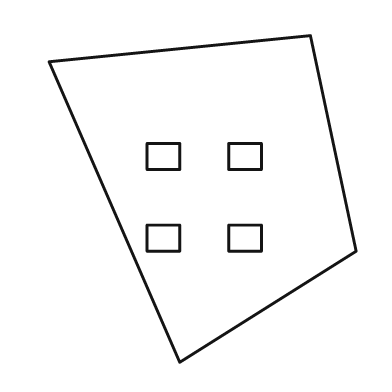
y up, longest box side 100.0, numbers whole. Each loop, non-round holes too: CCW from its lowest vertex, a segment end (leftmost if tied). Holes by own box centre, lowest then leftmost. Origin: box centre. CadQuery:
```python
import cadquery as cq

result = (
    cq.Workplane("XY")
    .moveTo(-7.0, -50.0)
    .lineTo(47.0, -16.0)
    .lineTo(33.0, 50.0)
    .lineTo(-47.0, 42.0)
    .close()
    .moveTo(-17.0, -16.0)
    .lineTo(-7.0, -16.0)
    .lineTo(-7.0, -8.0)
    .lineTo(-17.0, -8.0)
    .close()
    .moveTo(8.0, -16.0)
    .lineTo(18.0, -16.0)
    .lineTo(18.0, -8.0)
    .lineTo(8.0, -8.0)
    .close()
    .moveTo(-17.0, 9.0)
    .lineTo(-7.0, 9.0)
    .lineTo(-7.0, 17.0)
    .lineTo(-17.0, 17.0)
    .close()
    .moveTo(8.0, 9.0)
    .lineTo(18.0, 9.0)
    .lineTo(18.0, 17.0)
    .lineTo(8.0, 17.0)
    .close()
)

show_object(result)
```